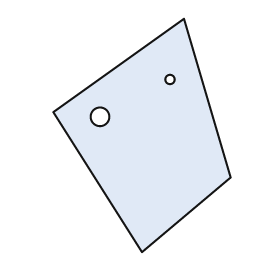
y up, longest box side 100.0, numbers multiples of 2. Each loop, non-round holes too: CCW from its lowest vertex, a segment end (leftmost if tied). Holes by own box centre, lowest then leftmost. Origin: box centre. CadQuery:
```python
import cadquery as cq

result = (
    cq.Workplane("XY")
    .moveTo(0.0, -50.0)
    .lineTo(38.0, -18.0)
    .lineTo(18.0, 50.0)
    .lineTo(-38.0, 10.0)
    .close()
    .moveTo(-18.0, 8.0)
    .circle(4.0)
    .moveTo(12.0, 24.0)
    .circle(2.0)
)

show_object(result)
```